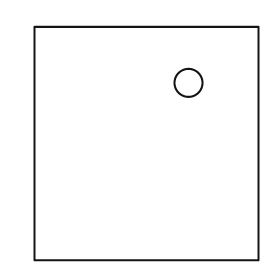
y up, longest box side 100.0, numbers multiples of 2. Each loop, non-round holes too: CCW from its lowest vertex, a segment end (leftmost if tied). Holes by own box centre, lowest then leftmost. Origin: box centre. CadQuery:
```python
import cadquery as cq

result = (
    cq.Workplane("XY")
    .moveTo(-48.0, -50.0)
    .lineTo(48.0, -50.0)
    .lineTo(48.0, 50.0)
    .lineTo(-48.0, 50.0)
    .close()
    .moveTo(18.0, 26.0)
    .circle(6.0)
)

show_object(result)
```